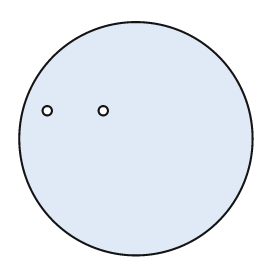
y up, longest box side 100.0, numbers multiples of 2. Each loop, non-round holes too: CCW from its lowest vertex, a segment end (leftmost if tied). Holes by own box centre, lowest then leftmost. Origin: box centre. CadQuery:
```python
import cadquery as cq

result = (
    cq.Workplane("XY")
    .moveTo(0.0, 0.0)
    .circle(50.0)
    .moveTo(-38.0, 12.0)
    .circle(2.0)
    .moveTo(-14.0, 12.0)
    .circle(2.0)
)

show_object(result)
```